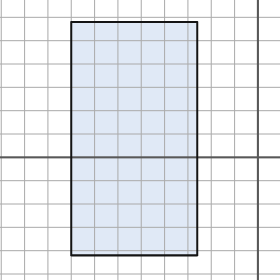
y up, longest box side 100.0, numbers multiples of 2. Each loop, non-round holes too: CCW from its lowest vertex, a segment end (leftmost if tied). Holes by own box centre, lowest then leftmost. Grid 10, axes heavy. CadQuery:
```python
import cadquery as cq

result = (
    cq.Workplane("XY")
    .moveTo(-80.0, -42.0)
    .lineTo(-26.0, -42.0)
    .lineTo(-26.0, 58.0)
    .lineTo(-80.0, 58.0)
    .close()
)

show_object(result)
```